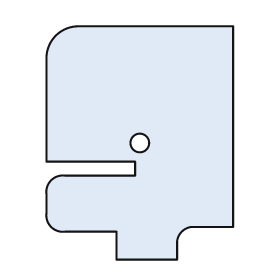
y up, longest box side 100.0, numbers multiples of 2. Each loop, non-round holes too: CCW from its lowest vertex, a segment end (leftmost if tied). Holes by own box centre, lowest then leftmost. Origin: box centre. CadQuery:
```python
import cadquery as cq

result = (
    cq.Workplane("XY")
    .moveTo(-10.0, -50.0)
    .lineTo(16.0, -50.0)
    .lineTo(16.0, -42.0)
    .threePointArc((18.0, -38.0), (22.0, -36.0))
    .lineTo(40.0, -36.0)
    .lineTo(40.0, 50.0)
    .lineTo(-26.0, 50.0)
    .threePointArc((-36.0, 46.0), (-40.0, 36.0))
    .lineTo(-40.0, -8.0)
    .lineTo(-2.0, -8.0)
    .lineTo(-2.0, -14.0)
    .lineTo(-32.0, -14.0)
    .threePointArc((-38.0, -16.0), (-40.0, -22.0))
    .lineTo(-40.0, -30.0)
    .threePointArc((-38.0, -36.0), (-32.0, -38.0))
    .lineTo(-10.0, -38.0)
    .close()
    .moveTo(0.0, 0.0)
    .circle(4.0)
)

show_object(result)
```